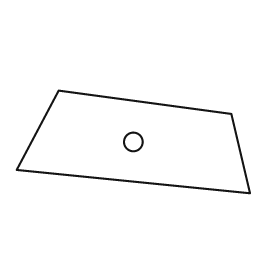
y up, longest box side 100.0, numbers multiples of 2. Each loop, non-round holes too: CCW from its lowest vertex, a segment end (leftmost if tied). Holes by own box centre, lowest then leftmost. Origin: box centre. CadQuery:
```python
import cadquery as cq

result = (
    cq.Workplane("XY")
    .moveTo(50.0, -22.0)
    .lineTo(42.0, 12.0)
    .lineTo(-32.0, 22.0)
    .lineTo(-50.0, -12.0)
    .close()
    .moveTo(0.0, 0.0)
    .circle(4.0)
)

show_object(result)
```